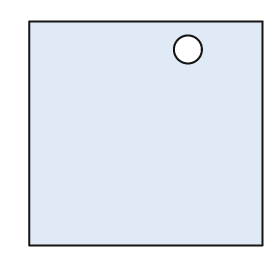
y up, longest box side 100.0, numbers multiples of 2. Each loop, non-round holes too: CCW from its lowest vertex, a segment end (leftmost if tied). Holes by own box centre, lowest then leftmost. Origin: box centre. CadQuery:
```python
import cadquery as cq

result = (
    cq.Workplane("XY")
    .moveTo(-50.0, -48.0)
    .lineTo(50.0, -48.0)
    .lineTo(50.0, 48.0)
    .lineTo(-50.0, 48.0)
    .close()
    .moveTo(18.0, 36.0)
    .circle(6.0)
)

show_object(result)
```